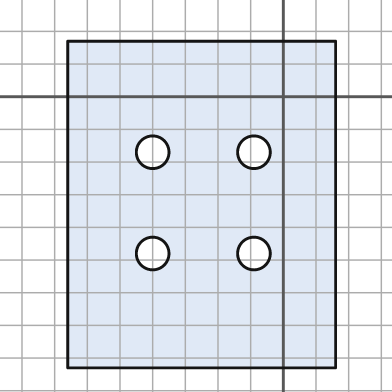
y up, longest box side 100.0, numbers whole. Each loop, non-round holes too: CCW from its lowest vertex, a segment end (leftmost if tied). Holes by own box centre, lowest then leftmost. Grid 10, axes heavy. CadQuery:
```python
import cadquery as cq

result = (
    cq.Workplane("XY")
    .moveTo(-66.0, -83.0)
    .lineTo(16.0, -83.0)
    .lineTo(16.0, 17.0)
    .lineTo(-66.0, 17.0)
    .close()
    .moveTo(-40.0, -48.0)
    .circle(5.0)
    .moveTo(-9.0, -48.0)
    .circle(5.0)
    .moveTo(-40.0, -17.0)
    .circle(5.0)
    .moveTo(-9.0, -17.0)
    .circle(5.0)
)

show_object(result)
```